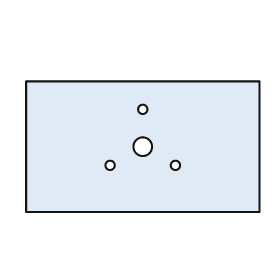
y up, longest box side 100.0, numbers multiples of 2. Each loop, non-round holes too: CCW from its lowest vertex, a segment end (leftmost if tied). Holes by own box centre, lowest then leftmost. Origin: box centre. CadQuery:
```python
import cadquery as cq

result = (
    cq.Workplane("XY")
    .moveTo(-50.0, -28.0)
    .lineTo(50.0, -28.0)
    .lineTo(50.0, 28.0)
    .lineTo(-50.0, 28.0)
    .close()
    .moveTo(-14.0, -8.0)
    .circle(2.0)
    .moveTo(14.0, -8.0)
    .circle(2.0)
    .moveTo(0.0, 0.0)
    .circle(4.0)
    .moveTo(0.0, 16.0)
    .circle(2.0)
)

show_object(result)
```